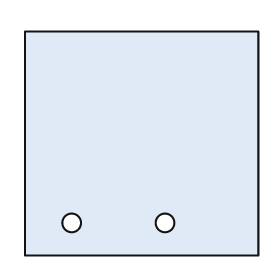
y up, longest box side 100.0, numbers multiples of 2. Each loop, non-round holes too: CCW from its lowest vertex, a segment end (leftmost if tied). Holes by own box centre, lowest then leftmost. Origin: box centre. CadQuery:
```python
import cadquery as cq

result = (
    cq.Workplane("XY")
    .moveTo(-50.0, -48.0)
    .lineTo(50.0, -48.0)
    .lineTo(50.0, 48.0)
    .lineTo(-50.0, 48.0)
    .close()
    .moveTo(-30.0, -34.0)
    .circle(4.0)
    .moveTo(10.0, -34.0)
    .circle(4.0)
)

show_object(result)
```